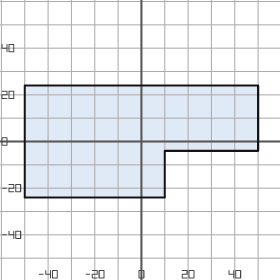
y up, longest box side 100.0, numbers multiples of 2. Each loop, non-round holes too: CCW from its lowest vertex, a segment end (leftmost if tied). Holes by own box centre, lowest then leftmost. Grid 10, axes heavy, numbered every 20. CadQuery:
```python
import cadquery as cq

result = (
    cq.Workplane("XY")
    .moveTo(-50.0, -24.0)
    .lineTo(10.0, -24.0)
    .lineTo(10.0, -4.0)
    .lineTo(50.0, -4.0)
    .lineTo(50.0, 24.0)
    .lineTo(-50.0, 24.0)
    .close()
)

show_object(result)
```